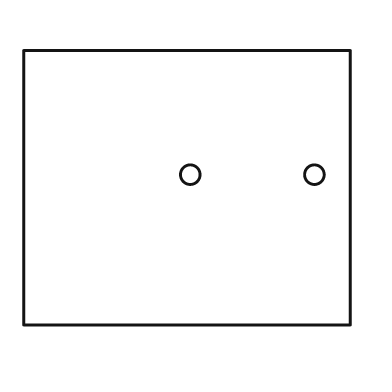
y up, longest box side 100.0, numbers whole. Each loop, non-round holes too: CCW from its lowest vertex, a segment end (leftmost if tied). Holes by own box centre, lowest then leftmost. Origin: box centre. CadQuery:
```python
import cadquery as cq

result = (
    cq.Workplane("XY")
    .moveTo(-50.0, -42.0)
    .lineTo(50.0, -42.0)
    .lineTo(50.0, 42.0)
    .lineTo(-50.0, 42.0)
    .close()
    .moveTo(1.0, 4.0)
    .circle(3.0)
    .moveTo(39.0, 4.0)
    .circle(3.0)
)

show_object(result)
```